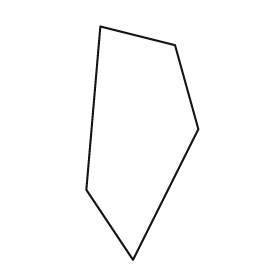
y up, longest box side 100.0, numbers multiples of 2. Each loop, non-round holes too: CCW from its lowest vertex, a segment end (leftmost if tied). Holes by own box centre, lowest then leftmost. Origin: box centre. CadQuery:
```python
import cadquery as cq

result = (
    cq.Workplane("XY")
    .moveTo(-4.0, -50.0)
    .lineTo(24.0, 6.0)
    .lineTo(14.0, 42.0)
    .lineTo(-18.0, 50.0)
    .lineTo(-24.0, -20.0)
    .close()
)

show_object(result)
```